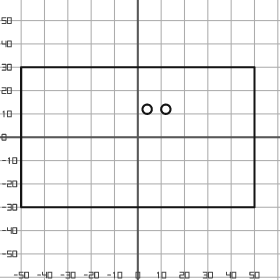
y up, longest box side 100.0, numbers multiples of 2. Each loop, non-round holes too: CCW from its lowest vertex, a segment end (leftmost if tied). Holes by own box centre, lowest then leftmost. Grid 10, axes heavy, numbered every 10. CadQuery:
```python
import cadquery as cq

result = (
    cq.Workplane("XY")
    .moveTo(-50.0, -30.0)
    .lineTo(50.0, -30.0)
    .lineTo(50.0, 30.0)
    .lineTo(-50.0, 30.0)
    .close()
    .moveTo(4.0, 12.0)
    .circle(2.0)
    .moveTo(12.0, 12.0)
    .circle(2.0)
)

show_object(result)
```